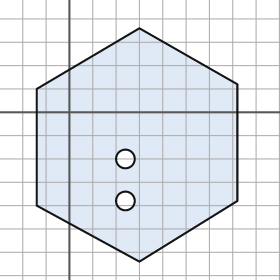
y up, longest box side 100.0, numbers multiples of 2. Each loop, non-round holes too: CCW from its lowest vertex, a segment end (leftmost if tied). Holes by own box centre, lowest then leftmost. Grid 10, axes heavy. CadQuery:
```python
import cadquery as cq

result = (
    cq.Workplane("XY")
    .moveTo(30.0, -64.0)
    .lineTo(72.0, -38.0)
    .lineTo(72.0, 12.0)
    .lineTo(30.0, 36.0)
    .lineTo(-14.0, 10.0)
    .lineTo(-14.0, -40.0)
    .close()
    .moveTo(24.0, -38.0)
    .circle(4.0)
    .moveTo(24.0, -20.0)
    .circle(4.0)
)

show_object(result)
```